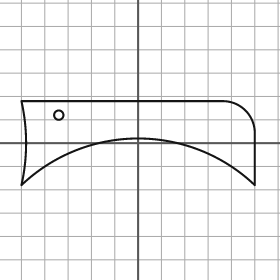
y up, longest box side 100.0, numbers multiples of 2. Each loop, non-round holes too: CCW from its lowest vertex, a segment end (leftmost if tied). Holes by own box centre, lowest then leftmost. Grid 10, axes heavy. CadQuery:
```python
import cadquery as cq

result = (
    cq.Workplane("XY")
    .moveTo(-50.0, -18.0)
    .threePointArc((0.0, 2.0), (50.0, -18.0))
    .lineTo(50.0, 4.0)
    .threePointArc((46.0, 14.0), (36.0, 18.0))
    .lineTo(-50.0, 18.0)
    .threePointArc((-48.0, 0.0), (-50.0, -18.0))
    .close()
    .moveTo(-34.0, 12.0)
    .circle(2.0)
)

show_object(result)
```